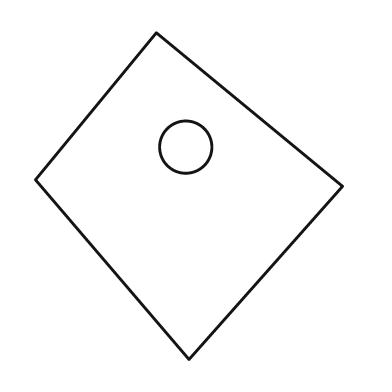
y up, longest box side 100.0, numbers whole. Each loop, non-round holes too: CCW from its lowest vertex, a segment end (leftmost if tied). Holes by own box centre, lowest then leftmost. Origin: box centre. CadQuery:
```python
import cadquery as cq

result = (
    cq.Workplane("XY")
    .moveTo(0.0, -50.0)
    .lineTo(47.0, 3.0)
    .lineTo(-10.0, 50.0)
    .lineTo(-47.0, 5.0)
    .close()
    .moveTo(-1.0, 15.0)
    .circle(8.0)
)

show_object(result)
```